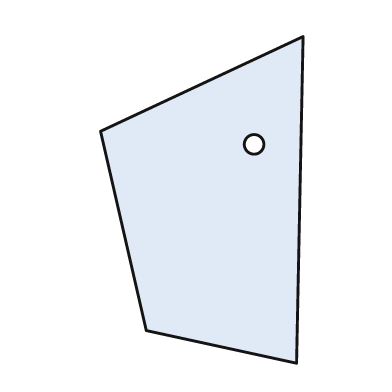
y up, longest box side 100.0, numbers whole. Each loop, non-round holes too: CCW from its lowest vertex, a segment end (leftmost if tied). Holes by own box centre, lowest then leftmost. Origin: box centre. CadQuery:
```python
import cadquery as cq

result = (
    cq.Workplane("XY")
    .moveTo(29.0, -50.0)
    .lineTo(31.0, 50.0)
    .lineTo(-31.0, 21.0)
    .lineTo(-17.0, -40.0)
    .close()
    .moveTo(16.0, 17.0)
    .circle(3.0)
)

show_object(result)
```